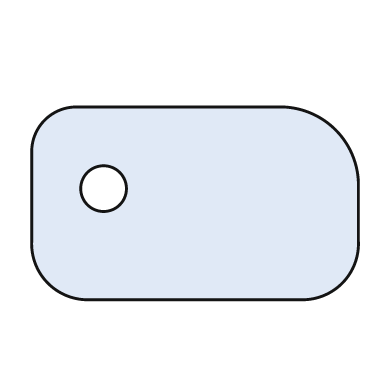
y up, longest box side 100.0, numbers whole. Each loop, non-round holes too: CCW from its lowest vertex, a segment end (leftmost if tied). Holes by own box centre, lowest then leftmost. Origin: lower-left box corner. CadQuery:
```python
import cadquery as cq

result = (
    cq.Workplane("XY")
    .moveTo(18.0, 0.0)
    .lineTo(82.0, 0.0)
    .threePointArc((95.0, 5.0), (100.0, 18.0))
    .lineTo(100.0, 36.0)
    .threePointArc((93.0, 52.0), (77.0, 59.0))
    .lineTo(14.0, 59.0)
    .threePointArc((4.0, 55.0), (0.0, 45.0))
    .lineTo(0.0, 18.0)
    .threePointArc((5.0, 5.0), (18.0, 0.0))
    .close()
    .moveTo(22.0, 34.0)
    .circle(7.0)
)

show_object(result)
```